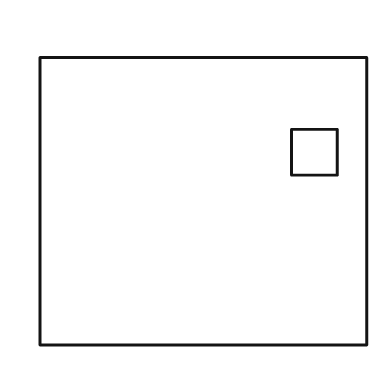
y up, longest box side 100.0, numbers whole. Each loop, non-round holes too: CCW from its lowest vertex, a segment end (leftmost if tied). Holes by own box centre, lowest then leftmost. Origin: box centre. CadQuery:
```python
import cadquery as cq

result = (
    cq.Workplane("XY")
    .moveTo(-50.0, -44.0)
    .lineTo(50.0, -44.0)
    .lineTo(50.0, 44.0)
    .lineTo(-50.0, 44.0)
    .close()
    .moveTo(27.0, 8.0)
    .lineTo(41.0, 8.0)
    .lineTo(41.0, 22.0)
    .lineTo(27.0, 22.0)
    .close()
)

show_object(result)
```